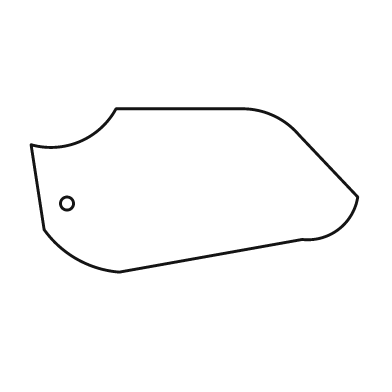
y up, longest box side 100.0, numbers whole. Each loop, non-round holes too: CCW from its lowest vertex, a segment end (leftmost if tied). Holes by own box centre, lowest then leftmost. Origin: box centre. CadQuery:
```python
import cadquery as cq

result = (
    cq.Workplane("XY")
    .moveTo(-23.0, -25.0)
    .lineTo(33.0, -15.0)
    .threePointArc((44.0, -12.0), (50.0, -2.0))
    .lineTo(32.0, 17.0)
    .threePointArc((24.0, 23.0), (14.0, 25.0))
    .lineTo(-24.0, 25.0)
    .threePointArc((-35.0, 15.0), (-50.0, 14.0))
    .lineTo(-46.0, -12.0)
    .threePointArc((-36.0, -21.0), (-23.0, -25.0))
    .close()
    .moveTo(-39.0, -4.0)
    .circle(2.0)
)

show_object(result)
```